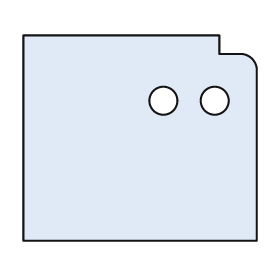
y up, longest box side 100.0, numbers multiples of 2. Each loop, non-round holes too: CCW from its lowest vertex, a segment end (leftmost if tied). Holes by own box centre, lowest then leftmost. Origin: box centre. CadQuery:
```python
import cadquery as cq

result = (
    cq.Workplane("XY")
    .moveTo(-50.0, -44.0)
    .lineTo(50.0, -44.0)
    .lineTo(50.0, 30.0)
    .threePointArc((48.0, 34.0), (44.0, 36.0))
    .lineTo(34.0, 36.0)
    .lineTo(34.0, 44.0)
    .lineTo(-50.0, 44.0)
    .close()
    .moveTo(10.0, 16.0)
    .circle(6.0)
    .moveTo(32.0, 16.0)
    .circle(6.0)
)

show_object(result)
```